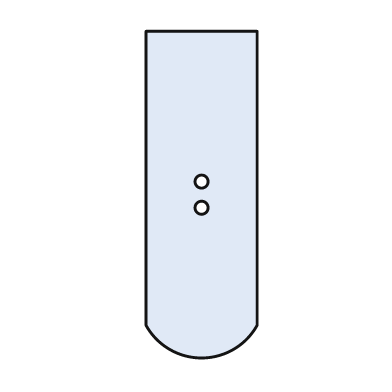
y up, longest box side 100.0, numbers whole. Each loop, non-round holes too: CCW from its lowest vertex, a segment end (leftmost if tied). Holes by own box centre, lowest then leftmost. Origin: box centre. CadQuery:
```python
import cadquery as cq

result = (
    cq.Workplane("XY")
    .moveTo(-17.0, -40.0)
    .threePointArc((0.0, -50.0), (17.0, -40.0))
    .lineTo(17.0, 50.0)
    .lineTo(-17.0, 50.0)
    .close()
    .moveTo(0.0, -4.0)
    .circle(2.0)
    .moveTo(0.0, 4.0)
    .circle(2.0)
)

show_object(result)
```